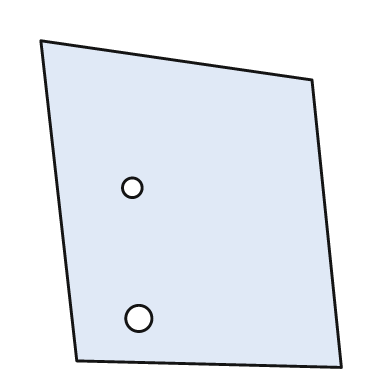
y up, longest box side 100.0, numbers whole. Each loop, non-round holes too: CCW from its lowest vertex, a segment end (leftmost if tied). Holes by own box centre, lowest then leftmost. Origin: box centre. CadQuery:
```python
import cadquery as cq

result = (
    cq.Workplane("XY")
    .moveTo(46.0, -50.0)
    .lineTo(37.0, 38.0)
    .lineTo(-46.0, 50.0)
    .lineTo(-35.0, -48.0)
    .close()
    .moveTo(-16.0, -35.0)
    .circle(4.0)
    .moveTo(-18.0, 5.0)
    .circle(3.0)
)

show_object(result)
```